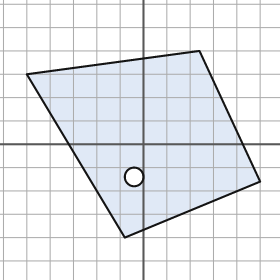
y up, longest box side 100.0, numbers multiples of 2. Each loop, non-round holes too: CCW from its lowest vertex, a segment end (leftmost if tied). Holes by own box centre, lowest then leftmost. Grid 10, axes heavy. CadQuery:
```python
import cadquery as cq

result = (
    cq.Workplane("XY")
    .moveTo(-8.0, -40.0)
    .lineTo(50.0, -16.0)
    .lineTo(24.0, 40.0)
    .lineTo(-50.0, 30.0)
    .close()
    .moveTo(-4.0, -14.0)
    .circle(4.0)
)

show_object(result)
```